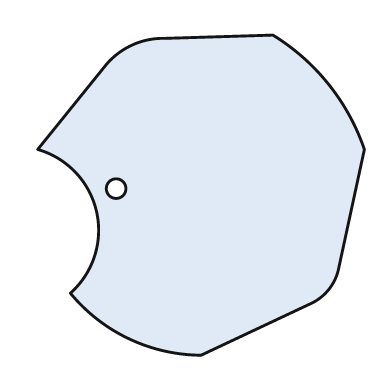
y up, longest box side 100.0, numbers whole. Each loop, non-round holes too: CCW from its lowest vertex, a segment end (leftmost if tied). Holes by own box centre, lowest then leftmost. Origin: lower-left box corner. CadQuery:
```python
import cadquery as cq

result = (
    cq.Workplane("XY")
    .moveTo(50.0, 0.0)
    .lineTo(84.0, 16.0)
    .threePointArc((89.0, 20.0), (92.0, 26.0))
    .lineTo(100.0, 63.0)
    .threePointArc((89.0, 83.0), (72.0, 98.0))
    .lineTo(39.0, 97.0)
    .threePointArc((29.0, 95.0), (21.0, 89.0))
    .lineTo(0.0, 63.0)
    .threePointArc((18.0, 44.0), (10.0, 19.0))
    .threePointArc((28.0, 5.0), (50.0, 0.0))
    .close()
    .moveTo(24.0, 51.0)
    .circle(3.0)
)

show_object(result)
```